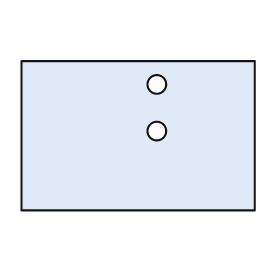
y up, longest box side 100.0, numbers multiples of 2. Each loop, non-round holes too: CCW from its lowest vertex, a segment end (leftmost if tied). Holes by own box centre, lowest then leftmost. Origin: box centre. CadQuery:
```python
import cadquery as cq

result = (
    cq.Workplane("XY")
    .moveTo(-50.0, -32.0)
    .lineTo(50.0, -32.0)
    .lineTo(50.0, 32.0)
    .lineTo(-50.0, 32.0)
    .close()
    .moveTo(8.0, 2.0)
    .circle(4.0)
    .moveTo(8.0, 22.0)
    .circle(4.0)
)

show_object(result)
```